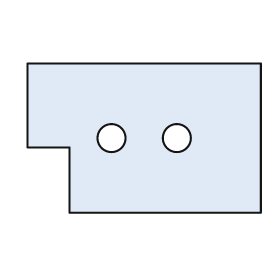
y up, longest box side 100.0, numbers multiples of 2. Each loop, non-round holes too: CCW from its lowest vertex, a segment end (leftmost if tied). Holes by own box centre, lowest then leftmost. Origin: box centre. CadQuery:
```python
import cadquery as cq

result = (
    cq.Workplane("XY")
    .moveTo(-32.0, -32.0)
    .lineTo(50.0, -32.0)
    .lineTo(50.0, 32.0)
    .lineTo(-50.0, 32.0)
    .lineTo(-50.0, -4.0)
    .lineTo(-32.0, -4.0)
    .close()
    .moveTo(-14.0, 0.0)
    .circle(6.0)
    .moveTo(14.0, 0.0)
    .circle(6.0)
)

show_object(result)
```